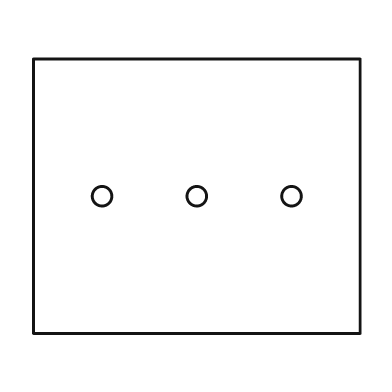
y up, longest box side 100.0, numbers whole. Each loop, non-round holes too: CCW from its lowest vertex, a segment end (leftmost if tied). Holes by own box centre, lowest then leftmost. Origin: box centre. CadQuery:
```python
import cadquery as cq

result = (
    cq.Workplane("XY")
    .moveTo(-50.0, -42.0)
    .lineTo(50.0, -42.0)
    .lineTo(50.0, 42.0)
    .lineTo(-50.0, 42.0)
    .close()
    .moveTo(-29.0, 0.0)
    .circle(3.0)
    .moveTo(0.0, 0.0)
    .circle(3.0)
    .moveTo(29.0, 0.0)
    .circle(3.0)
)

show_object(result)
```